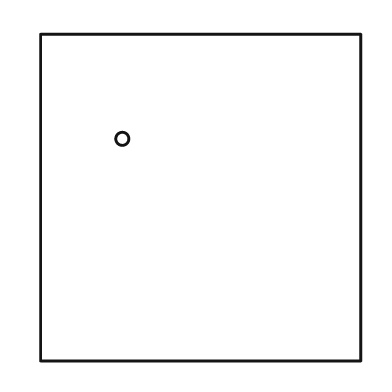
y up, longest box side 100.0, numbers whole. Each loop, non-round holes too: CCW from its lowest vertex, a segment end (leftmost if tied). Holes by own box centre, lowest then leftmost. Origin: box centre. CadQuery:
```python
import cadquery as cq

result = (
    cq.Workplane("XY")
    .moveTo(-49.0, -50.0)
    .lineTo(49.0, -50.0)
    .lineTo(49.0, 50.0)
    .lineTo(-49.0, 50.0)
    .close()
    .moveTo(-24.0, 18.0)
    .circle(2.0)
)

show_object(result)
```